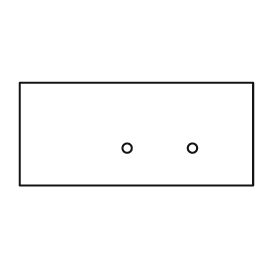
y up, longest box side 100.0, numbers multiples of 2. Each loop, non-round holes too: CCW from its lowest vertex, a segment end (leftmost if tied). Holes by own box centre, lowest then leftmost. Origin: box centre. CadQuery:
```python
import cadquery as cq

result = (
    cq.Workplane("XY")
    .moveTo(-50.0, -22.0)
    .lineTo(50.0, -22.0)
    .lineTo(50.0, 22.0)
    .lineTo(-50.0, 22.0)
    .close()
    .moveTo(-4.0, -6.0)
    .circle(2.0)
    .moveTo(24.0, -6.0)
    .circle(2.0)
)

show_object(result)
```